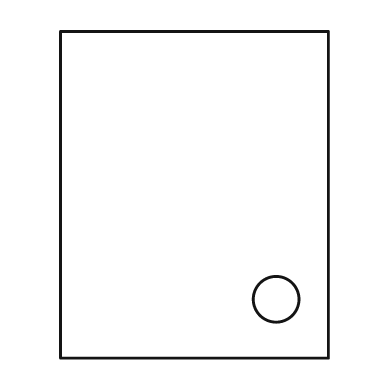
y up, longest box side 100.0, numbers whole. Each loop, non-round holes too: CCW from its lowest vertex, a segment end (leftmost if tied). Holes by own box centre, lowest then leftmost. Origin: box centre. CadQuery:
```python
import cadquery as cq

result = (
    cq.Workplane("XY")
    .moveTo(-41.0, -50.0)
    .lineTo(41.0, -50.0)
    .lineTo(41.0, 50.0)
    .lineTo(-41.0, 50.0)
    .close()
    .moveTo(25.0, -32.0)
    .circle(7.0)
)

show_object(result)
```